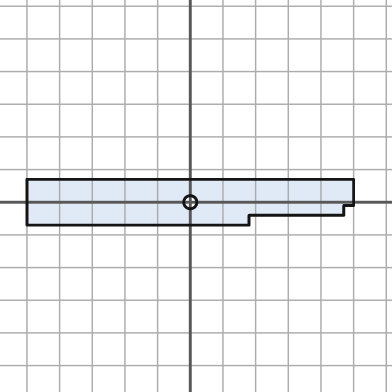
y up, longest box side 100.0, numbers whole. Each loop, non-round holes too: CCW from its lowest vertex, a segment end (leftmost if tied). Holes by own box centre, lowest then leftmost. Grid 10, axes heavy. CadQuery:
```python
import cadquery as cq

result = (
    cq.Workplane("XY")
    .moveTo(-50.0, -7.0)
    .lineTo(18.0, -7.0)
    .lineTo(18.0, -4.0)
    .lineTo(47.0, -4.0)
    .lineTo(47.0, -1.0)
    .lineTo(50.0, -1.0)
    .lineTo(50.0, 7.0)
    .lineTo(-50.0, 7.0)
    .close()
    .moveTo(0.0, 0.0)
    .circle(2.0)
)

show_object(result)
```